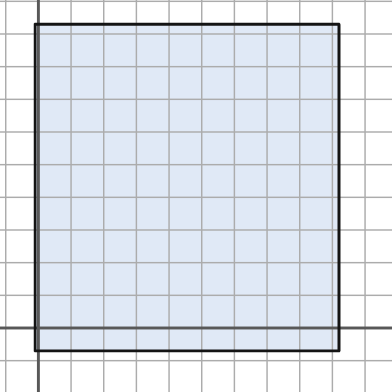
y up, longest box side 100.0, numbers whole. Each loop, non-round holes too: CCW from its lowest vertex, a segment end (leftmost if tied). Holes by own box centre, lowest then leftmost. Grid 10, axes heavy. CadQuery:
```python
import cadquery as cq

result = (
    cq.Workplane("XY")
    .moveTo(-1.0, -7.0)
    .lineTo(92.0, -7.0)
    .lineTo(92.0, 93.0)
    .lineTo(-1.0, 93.0)
    .close()
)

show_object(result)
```